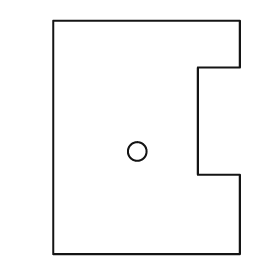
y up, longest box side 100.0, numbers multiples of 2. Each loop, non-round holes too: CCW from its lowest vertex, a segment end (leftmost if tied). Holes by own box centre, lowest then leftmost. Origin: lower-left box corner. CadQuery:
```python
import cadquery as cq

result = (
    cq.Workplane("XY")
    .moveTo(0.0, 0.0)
    .lineTo(80.0, 0.0)
    .lineTo(80.0, 34.0)
    .lineTo(62.0, 34.0)
    .lineTo(62.0, 80.0)
    .lineTo(80.0, 80.0)
    .lineTo(80.0, 100.0)
    .lineTo(0.0, 100.0)
    .close()
    .moveTo(36.0, 44.0)
    .circle(4.0)
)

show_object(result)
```